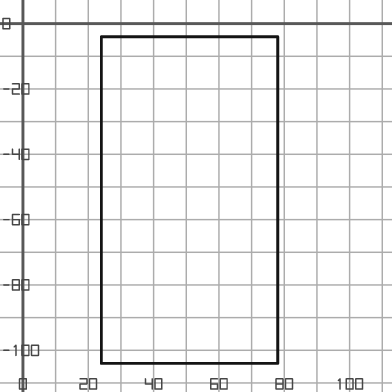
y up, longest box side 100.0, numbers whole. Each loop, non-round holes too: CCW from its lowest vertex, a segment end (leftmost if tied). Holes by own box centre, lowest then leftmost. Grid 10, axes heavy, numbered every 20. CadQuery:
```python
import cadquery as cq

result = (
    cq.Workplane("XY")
    .moveTo(24.0, -104.0)
    .lineTo(78.0, -104.0)
    .lineTo(78.0, -4.0)
    .lineTo(24.0, -4.0)
    .close()
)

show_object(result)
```